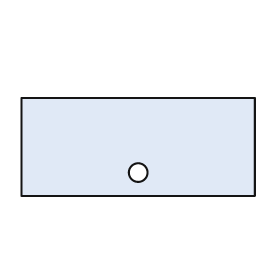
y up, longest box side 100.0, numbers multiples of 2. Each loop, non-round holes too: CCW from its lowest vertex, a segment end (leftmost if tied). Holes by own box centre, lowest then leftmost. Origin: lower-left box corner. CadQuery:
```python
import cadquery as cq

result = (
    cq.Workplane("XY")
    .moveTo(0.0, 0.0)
    .lineTo(100.0, 0.0)
    .lineTo(100.0, 42.0)
    .lineTo(0.0, 42.0)
    .close()
    .moveTo(50.0, 10.0)
    .circle(4.0)
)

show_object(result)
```